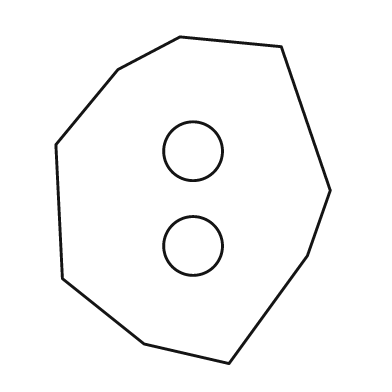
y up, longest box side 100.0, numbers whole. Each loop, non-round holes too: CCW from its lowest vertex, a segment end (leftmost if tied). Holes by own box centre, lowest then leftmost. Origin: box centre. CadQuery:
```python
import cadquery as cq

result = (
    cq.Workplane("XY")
    .moveTo(11.0, -50.0)
    .lineTo(35.0, -17.0)
    .lineTo(42.0, 3.0)
    .lineTo(27.0, 47.0)
    .lineTo(-4.0, 50.0)
    .lineTo(-23.0, 40.0)
    .lineTo(-42.0, 17.0)
    .lineTo(-40.0, -24.0)
    .lineTo(-15.0, -44.0)
    .close()
    .moveTo(0.0, -14.0)
    .circle(9.0)
    .moveTo(0.0, 15.0)
    .circle(9.0)
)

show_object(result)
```